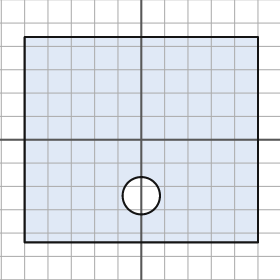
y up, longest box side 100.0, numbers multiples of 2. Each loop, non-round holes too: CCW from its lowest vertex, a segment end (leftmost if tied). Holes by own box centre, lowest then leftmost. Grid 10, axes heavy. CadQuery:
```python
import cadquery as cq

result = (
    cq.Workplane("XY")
    .moveTo(-50.0, -44.0)
    .lineTo(50.0, -44.0)
    .lineTo(50.0, 44.0)
    .lineTo(-50.0, 44.0)
    .close()
    .moveTo(0.0, -24.0)
    .circle(8.0)
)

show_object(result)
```